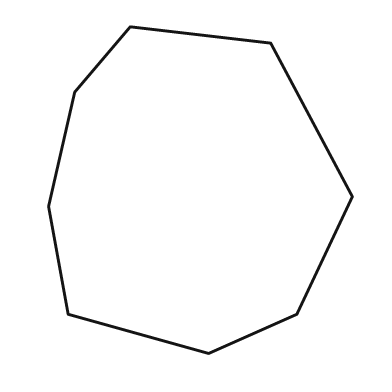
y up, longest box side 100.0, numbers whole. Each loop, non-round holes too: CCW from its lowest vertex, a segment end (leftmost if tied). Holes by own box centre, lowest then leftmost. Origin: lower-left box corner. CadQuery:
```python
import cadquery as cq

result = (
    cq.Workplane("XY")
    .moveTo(49.0, 0.0)
    .lineTo(76.0, 12.0)
    .lineTo(93.0, 48.0)
    .lineTo(68.0, 95.0)
    .lineTo(25.0, 100.0)
    .lineTo(8.0, 80.0)
    .lineTo(0.0, 45.0)
    .lineTo(6.0, 12.0)
    .close()
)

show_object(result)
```